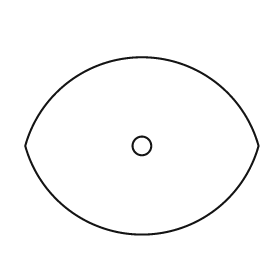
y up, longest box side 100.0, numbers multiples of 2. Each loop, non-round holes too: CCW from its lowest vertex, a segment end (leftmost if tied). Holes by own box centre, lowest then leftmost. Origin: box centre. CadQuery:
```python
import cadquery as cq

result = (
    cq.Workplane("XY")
    .moveTo(-50.0, 0.0)
    .threePointArc((0.0, -38.0), (50.0, 0.0))
    .threePointArc((0.0, 38.0), (-50.0, 0.0))
    .close()
    .moveTo(0.0, 0.0)
    .circle(4.0)
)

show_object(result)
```